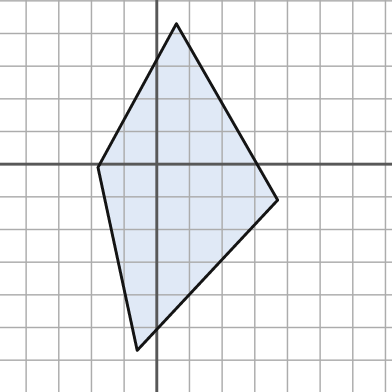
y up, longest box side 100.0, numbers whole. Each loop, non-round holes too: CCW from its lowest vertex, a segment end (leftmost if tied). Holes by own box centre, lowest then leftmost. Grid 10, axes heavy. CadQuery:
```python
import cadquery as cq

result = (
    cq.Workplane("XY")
    .moveTo(-6.0, -57.0)
    .lineTo(37.0, -11.0)
    .lineTo(6.0, 43.0)
    .lineTo(-18.0, -1.0)
    .close()
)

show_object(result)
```